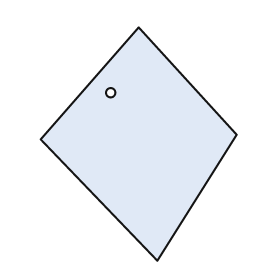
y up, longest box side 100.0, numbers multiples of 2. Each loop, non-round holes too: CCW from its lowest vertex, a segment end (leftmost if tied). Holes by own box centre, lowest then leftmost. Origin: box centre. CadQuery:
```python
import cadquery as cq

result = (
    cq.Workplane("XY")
    .moveTo(8.0, -50.0)
    .lineTo(42.0, 4.0)
    .lineTo(0.0, 50.0)
    .lineTo(-42.0, 2.0)
    .close()
    .moveTo(-12.0, 22.0)
    .circle(2.0)
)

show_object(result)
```